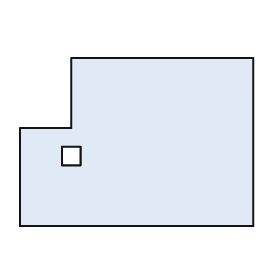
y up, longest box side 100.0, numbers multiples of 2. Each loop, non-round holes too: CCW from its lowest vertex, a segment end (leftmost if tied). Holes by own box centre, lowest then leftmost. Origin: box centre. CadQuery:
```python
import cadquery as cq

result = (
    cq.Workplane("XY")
    .moveTo(-50.0, -36.0)
    .lineTo(50.0, -36.0)
    .lineTo(50.0, 36.0)
    .lineTo(-28.0, 36.0)
    .lineTo(-28.0, 6.0)
    .lineTo(-50.0, 6.0)
    .close()
    .moveTo(-32.0, -10.0)
    .lineTo(-24.0, -10.0)
    .lineTo(-24.0, -2.0)
    .lineTo(-32.0, -2.0)
    .close()
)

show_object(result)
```